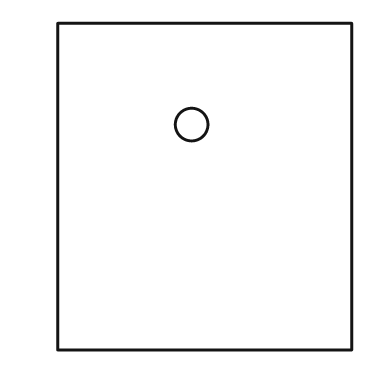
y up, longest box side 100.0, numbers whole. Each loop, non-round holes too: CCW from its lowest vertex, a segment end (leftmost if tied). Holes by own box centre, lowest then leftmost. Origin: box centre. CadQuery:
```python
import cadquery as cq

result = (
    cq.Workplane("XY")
    .moveTo(-45.0, -50.0)
    .lineTo(45.0, -50.0)
    .lineTo(45.0, 50.0)
    .lineTo(-45.0, 50.0)
    .close()
    .moveTo(-4.0, 19.0)
    .circle(5.0)
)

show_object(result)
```